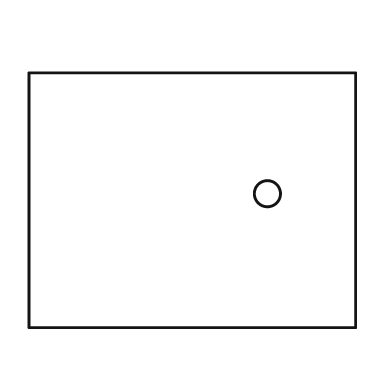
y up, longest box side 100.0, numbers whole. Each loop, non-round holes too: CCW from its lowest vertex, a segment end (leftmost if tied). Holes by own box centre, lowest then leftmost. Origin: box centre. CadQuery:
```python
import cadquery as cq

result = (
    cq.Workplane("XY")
    .moveTo(-50.0, -39.0)
    .lineTo(50.0, -39.0)
    .lineTo(50.0, 39.0)
    .lineTo(-50.0, 39.0)
    .close()
    .moveTo(23.0, 2.0)
    .circle(4.0)
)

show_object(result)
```